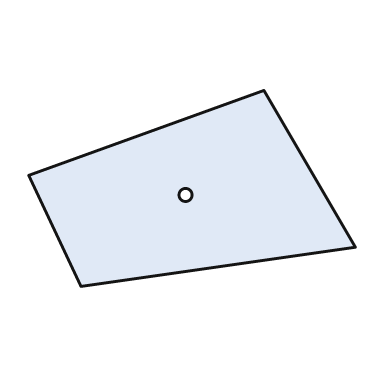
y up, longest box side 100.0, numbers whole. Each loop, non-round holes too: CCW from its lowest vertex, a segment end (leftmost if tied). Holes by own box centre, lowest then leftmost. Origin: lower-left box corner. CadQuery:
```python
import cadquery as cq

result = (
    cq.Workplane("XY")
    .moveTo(16.0, 0.0)
    .lineTo(100.0, 12.0)
    .lineTo(72.0, 60.0)
    .lineTo(0.0, 34.0)
    .close()
    .moveTo(48.0, 28.0)
    .circle(2.0)
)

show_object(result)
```